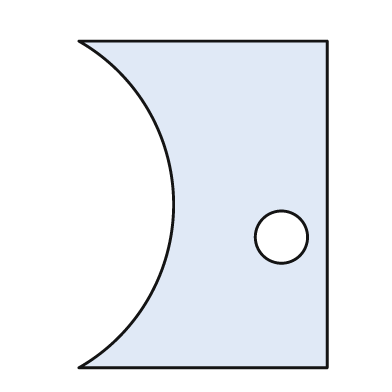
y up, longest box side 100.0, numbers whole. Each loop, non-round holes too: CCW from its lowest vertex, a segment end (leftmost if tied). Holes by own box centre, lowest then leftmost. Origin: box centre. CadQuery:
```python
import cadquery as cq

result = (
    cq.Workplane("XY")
    .moveTo(-38.0, -50.0)
    .lineTo(38.0, -50.0)
    .lineTo(38.0, 50.0)
    .lineTo(-38.0, 50.0)
    .threePointArc((-9.0, 0.0), (-38.0, -50.0))
    .close()
    .moveTo(24.0, -10.0)
    .circle(8.0)
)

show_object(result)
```